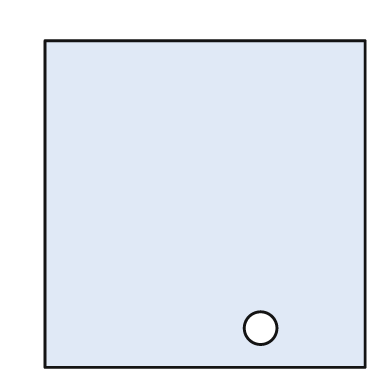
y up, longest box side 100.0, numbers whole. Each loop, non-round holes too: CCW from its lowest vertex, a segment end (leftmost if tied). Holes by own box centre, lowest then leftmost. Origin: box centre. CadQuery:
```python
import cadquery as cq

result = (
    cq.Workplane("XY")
    .moveTo(-49.0, -50.0)
    .lineTo(49.0, -50.0)
    .lineTo(49.0, 50.0)
    .lineTo(-49.0, 50.0)
    .close()
    .moveTo(17.0, -38.0)
    .circle(5.0)
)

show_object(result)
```